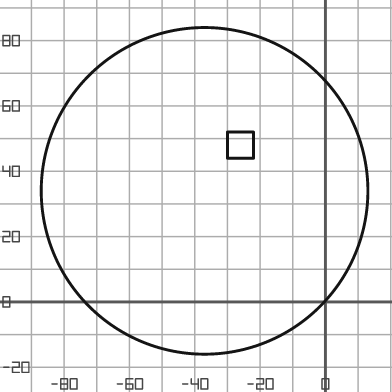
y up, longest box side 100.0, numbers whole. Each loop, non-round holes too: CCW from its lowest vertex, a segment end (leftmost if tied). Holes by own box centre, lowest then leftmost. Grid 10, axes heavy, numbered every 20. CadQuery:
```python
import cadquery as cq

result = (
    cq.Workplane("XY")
    .moveTo(-37.0, 34.0)
    .circle(50.0)
    .moveTo(-30.0, 44.0)
    .lineTo(-22.0, 44.0)
    .lineTo(-22.0, 52.0)
    .lineTo(-30.0, 52.0)
    .close()
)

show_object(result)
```